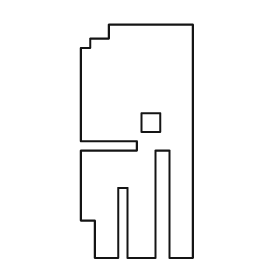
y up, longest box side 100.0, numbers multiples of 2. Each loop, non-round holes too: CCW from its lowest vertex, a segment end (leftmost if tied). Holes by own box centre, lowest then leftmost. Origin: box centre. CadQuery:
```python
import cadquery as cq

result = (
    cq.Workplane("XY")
    .moveTo(-18.0, -50.0)
    .lineTo(-8.0, -50.0)
    .lineTo(-8.0, -20.0)
    .lineTo(-4.0, -20.0)
    .lineTo(-4.0, -50.0)
    .lineTo(8.0, -50.0)
    .lineTo(8.0, -4.0)
    .lineTo(14.0, -4.0)
    .lineTo(14.0, -50.0)
    .lineTo(24.0, -50.0)
    .lineTo(24.0, 50.0)
    .lineTo(-12.0, 50.0)
    .lineTo(-12.0, 44.0)
    .lineTo(-20.0, 44.0)
    .lineTo(-20.0, 40.0)
    .lineTo(-24.0, 40.0)
    .lineTo(-24.0, 0.0)
    .lineTo(0.0, 0.0)
    .lineTo(0.0, -4.0)
    .lineTo(-24.0, -4.0)
    .lineTo(-24.0, -34.0)
    .lineTo(-18.0, -34.0)
    .close()
    .moveTo(2.0, 4.0)
    .lineTo(10.0, 4.0)
    .lineTo(10.0, 12.0)
    .lineTo(2.0, 12.0)
    .close()
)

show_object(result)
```